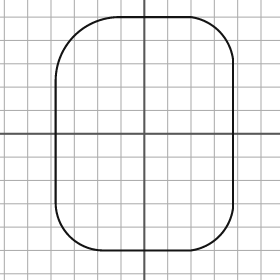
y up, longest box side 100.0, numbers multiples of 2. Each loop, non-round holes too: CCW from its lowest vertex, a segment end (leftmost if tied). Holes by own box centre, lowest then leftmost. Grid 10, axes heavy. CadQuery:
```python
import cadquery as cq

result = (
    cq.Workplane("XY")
    .moveTo(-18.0, -50.0)
    .lineTo(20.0, -50.0)
    .threePointArc((32.0, -44.0), (38.0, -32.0))
    .lineTo(38.0, 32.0)
    .threePointArc((32.0, 44.0), (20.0, 50.0))
    .lineTo(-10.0, 50.0)
    .threePointArc((-30.0, 42.0), (-38.0, 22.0))
    .lineTo(-38.0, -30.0)
    .threePointArc((-32.0, -44.0), (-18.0, -50.0))
    .close()
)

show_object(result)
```